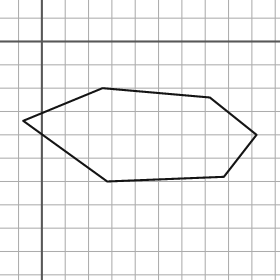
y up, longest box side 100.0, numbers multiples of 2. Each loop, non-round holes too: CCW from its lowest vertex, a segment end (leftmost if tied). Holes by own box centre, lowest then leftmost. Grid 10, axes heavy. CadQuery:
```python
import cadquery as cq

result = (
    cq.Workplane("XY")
    .moveTo(28.0, -60.0)
    .lineTo(78.0, -58.0)
    .lineTo(92.0, -40.0)
    .lineTo(72.0, -24.0)
    .lineTo(26.0, -20.0)
    .lineTo(-8.0, -34.0)
    .close()
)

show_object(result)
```